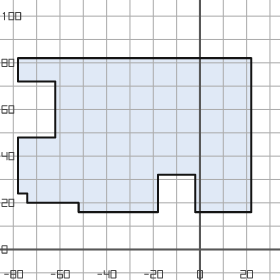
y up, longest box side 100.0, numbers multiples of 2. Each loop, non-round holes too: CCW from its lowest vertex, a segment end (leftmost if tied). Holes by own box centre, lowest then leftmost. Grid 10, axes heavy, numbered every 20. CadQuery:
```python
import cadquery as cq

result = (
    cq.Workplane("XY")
    .moveTo(-52.0, 16.0)
    .lineTo(-18.0, 16.0)
    .lineTo(-18.0, 32.0)
    .lineTo(-2.0, 32.0)
    .lineTo(-2.0, 16.0)
    .lineTo(22.0, 16.0)
    .lineTo(22.0, 82.0)
    .lineTo(-78.0, 82.0)
    .lineTo(-78.0, 72.0)
    .lineTo(-62.0, 72.0)
    .lineTo(-62.0, 48.0)
    .lineTo(-78.0, 48.0)
    .lineTo(-78.0, 24.0)
    .lineTo(-74.0, 24.0)
    .lineTo(-74.0, 20.0)
    .lineTo(-52.0, 20.0)
    .close()
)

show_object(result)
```